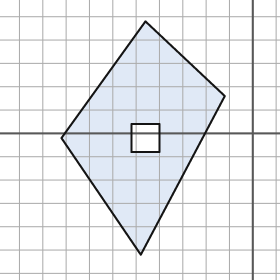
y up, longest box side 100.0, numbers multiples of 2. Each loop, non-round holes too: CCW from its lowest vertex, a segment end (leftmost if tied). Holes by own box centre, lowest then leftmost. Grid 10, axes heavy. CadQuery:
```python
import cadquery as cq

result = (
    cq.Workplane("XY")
    .moveTo(-48.0, -52.0)
    .lineTo(-12.0, 16.0)
    .lineTo(-46.0, 48.0)
    .lineTo(-82.0, -2.0)
    .close()
    .moveTo(-52.0, -8.0)
    .lineTo(-40.0, -8.0)
    .lineTo(-40.0, 4.0)
    .lineTo(-52.0, 4.0)
    .close()
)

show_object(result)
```